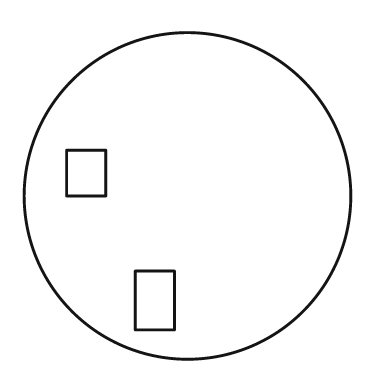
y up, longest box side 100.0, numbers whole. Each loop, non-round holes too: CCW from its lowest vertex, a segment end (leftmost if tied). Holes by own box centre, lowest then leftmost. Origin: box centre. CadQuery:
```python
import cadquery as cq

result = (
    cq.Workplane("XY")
    .moveTo(0.0, 0.0)
    .circle(50.0)
    .moveTo(-16.0, -41.0)
    .lineTo(-4.0, -41.0)
    .lineTo(-4.0, -23.0)
    .lineTo(-16.0, -23.0)
    .close()
    .moveTo(-37.0, 0.0)
    .lineTo(-25.0, 0.0)
    .lineTo(-25.0, 14.0)
    .lineTo(-37.0, 14.0)
    .close()
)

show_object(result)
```